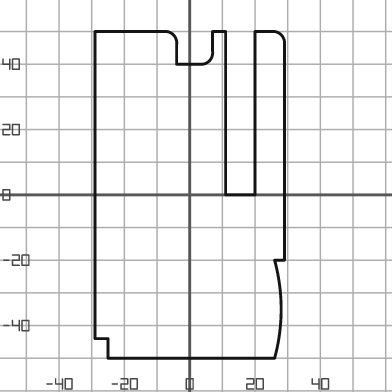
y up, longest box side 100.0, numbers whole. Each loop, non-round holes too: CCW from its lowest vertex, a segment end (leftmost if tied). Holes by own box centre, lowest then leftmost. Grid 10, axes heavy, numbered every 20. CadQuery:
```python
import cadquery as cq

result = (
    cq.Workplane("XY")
    .moveTo(-25.0, -50.0)
    .lineTo(26.0, -50.0)
    .threePointArc((28.0, -35.0), (26.0, -20.0))
    .lineTo(29.0, -20.0)
    .lineTo(29.0, 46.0)
    .threePointArc((28.0, 49.0), (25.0, 50.0))
    .lineTo(20.0, 50.0)
    .lineTo(20.0, 0.0)
    .lineTo(11.0, 0.0)
    .lineTo(11.0, 50.0)
    .lineTo(7.0, 50.0)
    .lineTo(7.0, 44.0)
    .threePointArc((6.0, 41.0), (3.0, 40.0))
    .lineTo(-4.0, 40.0)
    .lineTo(-4.0, 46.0)
    .threePointArc((-5.0, 49.0), (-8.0, 50.0))
    .lineTo(-29.0, 50.0)
    .lineTo(-29.0, -44.0)
    .lineTo(-25.0, -44.0)
    .close()
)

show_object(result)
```